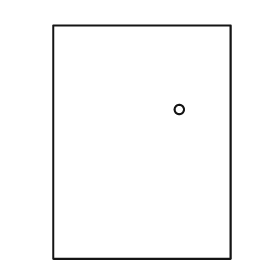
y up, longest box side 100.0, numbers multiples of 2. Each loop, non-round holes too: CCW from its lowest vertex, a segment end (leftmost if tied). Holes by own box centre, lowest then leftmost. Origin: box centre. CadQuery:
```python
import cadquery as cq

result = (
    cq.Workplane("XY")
    .moveTo(-38.0, -50.0)
    .lineTo(38.0, -50.0)
    .lineTo(38.0, 50.0)
    .lineTo(-38.0, 50.0)
    .close()
    .moveTo(16.0, 14.0)
    .circle(2.0)
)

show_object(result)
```